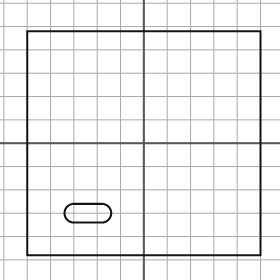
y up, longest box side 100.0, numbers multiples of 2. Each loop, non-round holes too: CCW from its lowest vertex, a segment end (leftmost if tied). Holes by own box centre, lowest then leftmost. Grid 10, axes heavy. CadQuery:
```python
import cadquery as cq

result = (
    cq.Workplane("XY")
    .moveTo(-50.0, -48.0)
    .lineTo(50.0, -48.0)
    .lineTo(50.0, 48.0)
    .lineTo(-50.0, 48.0)
    .close()
    .moveTo(-30.0, -34.0)
    .lineTo(-18.0, -34.0)
    .threePointArc((-14.0, -30.0), (-18.0, -26.0))
    .lineTo(-30.0, -26.0)
    .threePointArc((-34.0, -30.0), (-30.0, -34.0))
    .close()
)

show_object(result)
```